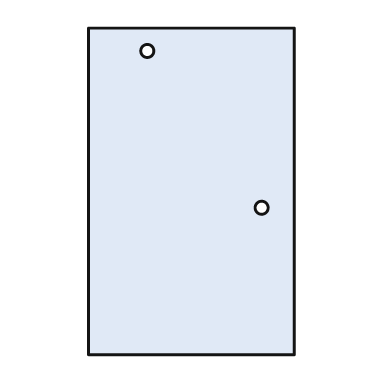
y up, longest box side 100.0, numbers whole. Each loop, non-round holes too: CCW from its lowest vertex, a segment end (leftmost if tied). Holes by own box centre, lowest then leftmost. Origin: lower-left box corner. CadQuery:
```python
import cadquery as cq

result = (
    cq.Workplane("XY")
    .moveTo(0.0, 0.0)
    .lineTo(63.0, 0.0)
    .lineTo(63.0, 100.0)
    .lineTo(0.0, 100.0)
    .close()
    .moveTo(53.0, 45.0)
    .circle(2.0)
    .moveTo(18.0, 93.0)
    .circle(2.0)
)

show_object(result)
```